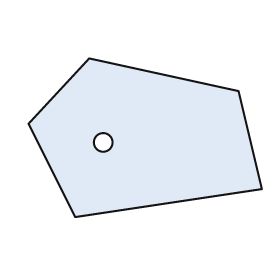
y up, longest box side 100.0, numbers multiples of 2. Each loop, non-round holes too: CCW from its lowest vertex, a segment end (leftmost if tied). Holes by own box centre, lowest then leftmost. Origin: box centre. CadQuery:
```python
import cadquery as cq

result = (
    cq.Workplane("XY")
    .moveTo(-30.0, -34.0)
    .lineTo(50.0, -22.0)
    .lineTo(40.0, 20.0)
    .lineTo(-24.0, 34.0)
    .lineTo(-50.0, 6.0)
    .close()
    .moveTo(-18.0, -2.0)
    .circle(4.0)
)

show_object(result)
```